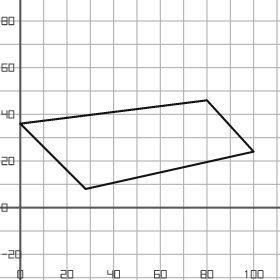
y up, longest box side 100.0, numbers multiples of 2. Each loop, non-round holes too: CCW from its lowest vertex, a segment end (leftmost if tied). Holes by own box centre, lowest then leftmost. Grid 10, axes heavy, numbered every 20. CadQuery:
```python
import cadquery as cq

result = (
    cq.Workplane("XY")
    .moveTo(28.0, 8.0)
    .lineTo(100.0, 24.0)
    .lineTo(80.0, 46.0)
    .lineTo(0.0, 36.0)
    .close()
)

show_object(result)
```